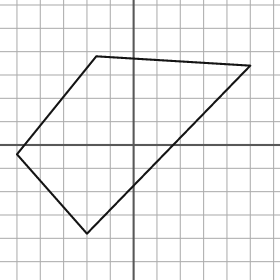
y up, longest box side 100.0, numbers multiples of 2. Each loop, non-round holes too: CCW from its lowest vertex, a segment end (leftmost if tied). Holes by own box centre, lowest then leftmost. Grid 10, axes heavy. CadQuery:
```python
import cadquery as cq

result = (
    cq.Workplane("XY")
    .moveTo(-20.0, -38.0)
    .lineTo(50.0, 34.0)
    .lineTo(-16.0, 38.0)
    .lineTo(-50.0, -4.0)
    .close()
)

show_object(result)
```